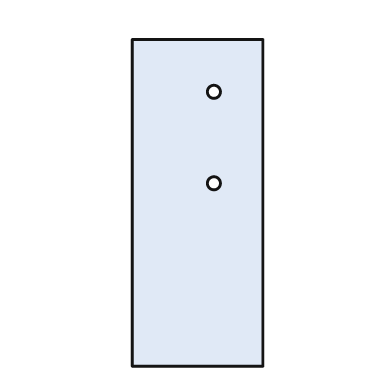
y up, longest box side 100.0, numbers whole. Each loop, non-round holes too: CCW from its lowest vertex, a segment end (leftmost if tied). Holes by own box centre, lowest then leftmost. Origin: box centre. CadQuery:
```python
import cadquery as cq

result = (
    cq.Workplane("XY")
    .moveTo(-20.0, -50.0)
    .lineTo(20.0, -50.0)
    .lineTo(20.0, 50.0)
    .lineTo(-20.0, 50.0)
    .close()
    .moveTo(5.0, 6.0)
    .circle(2.0)
    .moveTo(5.0, 34.0)
    .circle(2.0)
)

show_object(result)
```